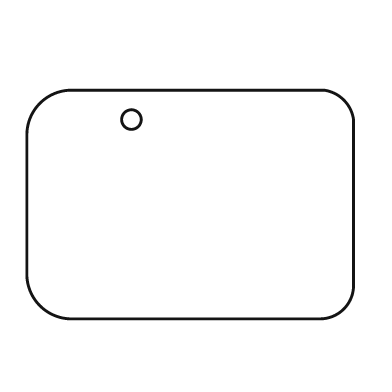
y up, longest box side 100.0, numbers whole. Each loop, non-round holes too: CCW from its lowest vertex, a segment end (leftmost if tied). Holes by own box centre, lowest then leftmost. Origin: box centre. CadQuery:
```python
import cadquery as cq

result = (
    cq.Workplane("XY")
    .moveTo(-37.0, -35.0)
    .lineTo(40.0, -35.0)
    .threePointArc((47.0, -32.0), (50.0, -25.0))
    .lineTo(50.0, 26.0)
    .threePointArc((47.0, 32.0), (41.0, 35.0))
    .lineTo(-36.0, 35.0)
    .threePointArc((-46.0, 31.0), (-50.0, 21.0))
    .lineTo(-50.0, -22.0)
    .threePointArc((-46.0, -31.0), (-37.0, -35.0))
    .close()
    .moveTo(-18.0, 26.0)
    .circle(3.0)
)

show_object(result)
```